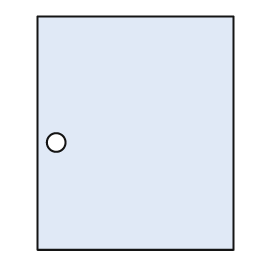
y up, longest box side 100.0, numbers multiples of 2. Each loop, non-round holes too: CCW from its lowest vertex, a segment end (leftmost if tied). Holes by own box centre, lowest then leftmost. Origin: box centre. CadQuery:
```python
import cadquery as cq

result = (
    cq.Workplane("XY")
    .moveTo(-42.0, -50.0)
    .lineTo(42.0, -50.0)
    .lineTo(42.0, 50.0)
    .lineTo(-42.0, 50.0)
    .close()
    .moveTo(-34.0, -4.0)
    .circle(4.0)
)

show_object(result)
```